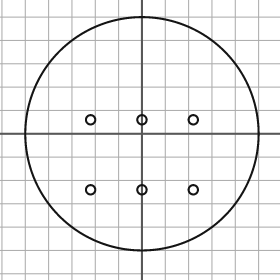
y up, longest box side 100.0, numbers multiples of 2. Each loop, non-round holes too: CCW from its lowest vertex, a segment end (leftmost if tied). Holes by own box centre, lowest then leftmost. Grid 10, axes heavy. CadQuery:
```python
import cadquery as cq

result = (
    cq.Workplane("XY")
    .moveTo(0.0, 0.0)
    .circle(50.0)
    .moveTo(-22.0, -24.0)
    .circle(2.0)
    .moveTo(0.0, -24.0)
    .circle(2.0)
    .moveTo(22.0, -24.0)
    .circle(2.0)
    .moveTo(-22.0, 6.0)
    .circle(2.0)
    .moveTo(0.0, 6.0)
    .circle(2.0)
    .moveTo(22.0, 6.0)
    .circle(2.0)
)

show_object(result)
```